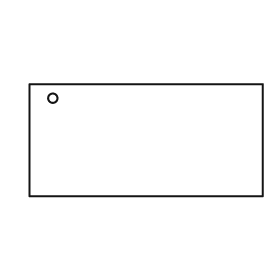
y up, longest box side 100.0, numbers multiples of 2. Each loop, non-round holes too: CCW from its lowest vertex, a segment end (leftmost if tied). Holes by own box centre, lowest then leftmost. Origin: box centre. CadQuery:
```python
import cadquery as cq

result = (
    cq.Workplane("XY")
    .moveTo(-50.0, -24.0)
    .lineTo(50.0, -24.0)
    .lineTo(50.0, 24.0)
    .lineTo(-50.0, 24.0)
    .close()
    .moveTo(-40.0, 18.0)
    .circle(2.0)
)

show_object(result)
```